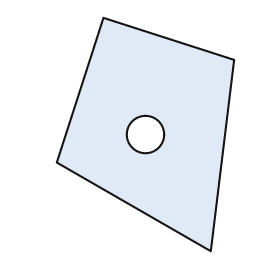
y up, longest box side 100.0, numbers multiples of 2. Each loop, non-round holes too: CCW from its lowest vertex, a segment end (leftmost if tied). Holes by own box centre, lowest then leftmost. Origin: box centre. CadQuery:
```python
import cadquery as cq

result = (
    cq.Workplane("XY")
    .moveTo(28.0, -50.0)
    .lineTo(38.0, 32.0)
    .lineTo(-18.0, 50.0)
    .lineTo(-38.0, -12.0)
    .close()
    .moveTo(0.0, 0.0)
    .circle(8.0)
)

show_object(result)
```